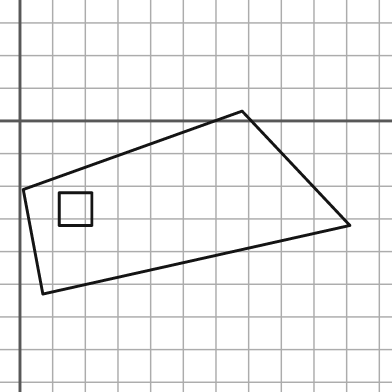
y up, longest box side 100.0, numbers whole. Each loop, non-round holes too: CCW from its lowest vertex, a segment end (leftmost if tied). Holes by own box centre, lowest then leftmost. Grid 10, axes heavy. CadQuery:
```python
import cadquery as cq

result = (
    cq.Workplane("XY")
    .moveTo(7.0, -53.0)
    .lineTo(101.0, -32.0)
    .lineTo(68.0, 3.0)
    .lineTo(1.0, -21.0)
    .close()
    .moveTo(12.0, -32.0)
    .lineTo(22.0, -32.0)
    .lineTo(22.0, -22.0)
    .lineTo(12.0, -22.0)
    .close()
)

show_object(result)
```